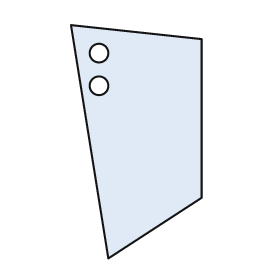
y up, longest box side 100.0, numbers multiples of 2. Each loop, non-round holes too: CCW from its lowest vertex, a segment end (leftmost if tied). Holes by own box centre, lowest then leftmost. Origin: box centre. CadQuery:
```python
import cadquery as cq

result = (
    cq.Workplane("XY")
    .moveTo(-12.0, -50.0)
    .lineTo(28.0, -24.0)
    .lineTo(28.0, 44.0)
    .lineTo(-28.0, 50.0)
    .close()
    .moveTo(-16.0, 24.0)
    .circle(4.0)
    .moveTo(-16.0, 38.0)
    .circle(4.0)
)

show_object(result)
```